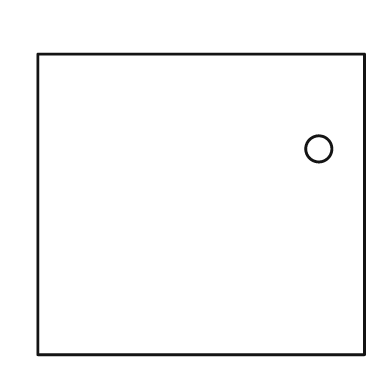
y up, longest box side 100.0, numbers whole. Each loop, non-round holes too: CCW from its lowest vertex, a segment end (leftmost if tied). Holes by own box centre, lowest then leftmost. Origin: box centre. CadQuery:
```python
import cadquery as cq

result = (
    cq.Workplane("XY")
    .moveTo(-50.0, -46.0)
    .lineTo(50.0, -46.0)
    .lineTo(50.0, 46.0)
    .lineTo(-50.0, 46.0)
    .close()
    .moveTo(36.0, 17.0)
    .circle(4.0)
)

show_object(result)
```